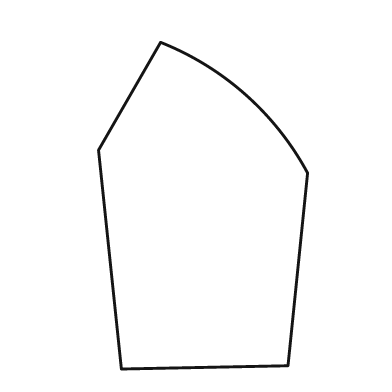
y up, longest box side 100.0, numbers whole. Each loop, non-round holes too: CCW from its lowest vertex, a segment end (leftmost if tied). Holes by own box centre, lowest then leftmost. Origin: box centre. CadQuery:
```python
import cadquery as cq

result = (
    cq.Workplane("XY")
    .moveTo(-25.0, -50.0)
    .lineTo(26.0, -49.0)
    .lineTo(32.0, 10.0)
    .threePointArc((13.0, 34.0), (-13.0, 50.0))
    .lineTo(-32.0, 17.0)
    .close()
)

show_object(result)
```